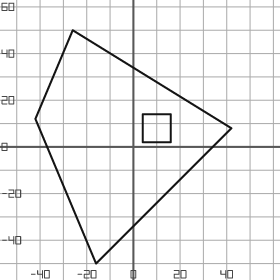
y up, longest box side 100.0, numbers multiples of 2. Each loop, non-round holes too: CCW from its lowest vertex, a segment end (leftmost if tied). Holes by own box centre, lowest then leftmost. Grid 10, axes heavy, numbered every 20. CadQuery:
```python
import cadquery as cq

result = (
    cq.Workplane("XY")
    .moveTo(-16.0, -50.0)
    .lineTo(42.0, 8.0)
    .lineTo(-26.0, 50.0)
    .lineTo(-42.0, 12.0)
    .close()
    .moveTo(4.0, 2.0)
    .lineTo(16.0, 2.0)
    .lineTo(16.0, 14.0)
    .lineTo(4.0, 14.0)
    .close()
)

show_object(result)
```